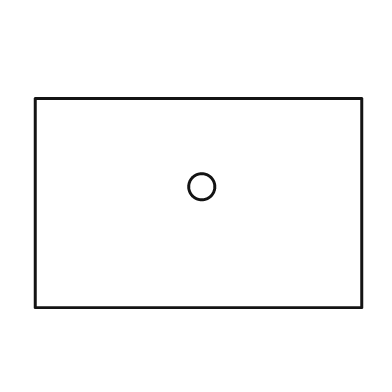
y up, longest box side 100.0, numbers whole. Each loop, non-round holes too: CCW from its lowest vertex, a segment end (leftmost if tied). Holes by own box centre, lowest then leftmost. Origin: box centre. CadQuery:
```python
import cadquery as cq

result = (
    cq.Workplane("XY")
    .moveTo(-50.0, -32.0)
    .lineTo(50.0, -32.0)
    .lineTo(50.0, 32.0)
    .lineTo(-50.0, 32.0)
    .close()
    .moveTo(1.0, 5.0)
    .circle(4.0)
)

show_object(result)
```